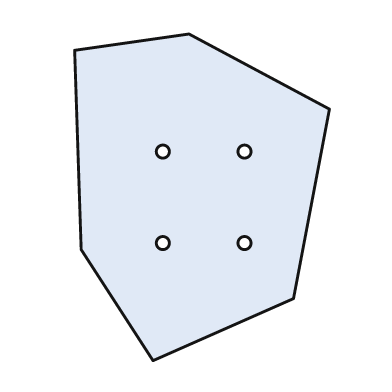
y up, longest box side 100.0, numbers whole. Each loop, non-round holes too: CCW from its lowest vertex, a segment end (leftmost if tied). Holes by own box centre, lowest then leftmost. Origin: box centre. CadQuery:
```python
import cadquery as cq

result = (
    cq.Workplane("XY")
    .moveTo(-15.0, -50.0)
    .lineTo(28.0, -31.0)
    .lineTo(39.0, 27.0)
    .lineTo(-4.0, 50.0)
    .lineTo(-39.0, 45.0)
    .lineTo(-37.0, -16.0)
    .close()
    .moveTo(-12.0, -14.0)
    .circle(2.0)
    .moveTo(13.0, -14.0)
    .circle(2.0)
    .moveTo(-12.0, 14.0)
    .circle(2.0)
    .moveTo(13.0, 14.0)
    .circle(2.0)
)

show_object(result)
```